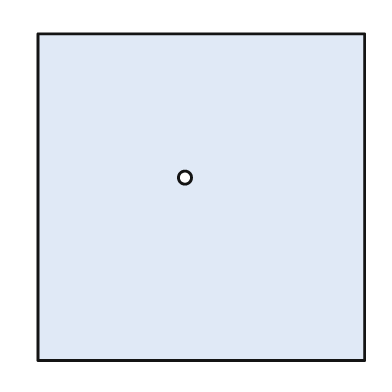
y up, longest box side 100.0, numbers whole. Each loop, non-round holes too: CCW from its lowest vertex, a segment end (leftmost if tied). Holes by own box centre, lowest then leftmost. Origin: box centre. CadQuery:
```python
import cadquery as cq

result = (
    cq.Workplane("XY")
    .moveTo(-50.0, -50.0)
    .lineTo(50.0, -50.0)
    .lineTo(50.0, 50.0)
    .lineTo(-50.0, 50.0)
    .close()
    .moveTo(-5.0, 6.0)
    .circle(2.0)
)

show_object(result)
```